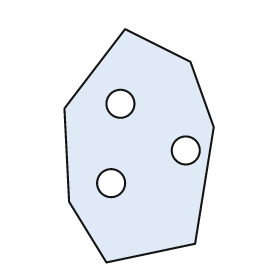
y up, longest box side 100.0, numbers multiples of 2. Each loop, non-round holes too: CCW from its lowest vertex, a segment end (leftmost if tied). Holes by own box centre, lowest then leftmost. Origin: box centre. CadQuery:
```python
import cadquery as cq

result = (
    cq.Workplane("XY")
    .moveTo(-14.0, -50.0)
    .lineTo(24.0, -42.0)
    .lineTo(32.0, 8.0)
    .lineTo(22.0, 36.0)
    .lineTo(-6.0, 50.0)
    .lineTo(-32.0, 16.0)
    .lineTo(-30.0, -24.0)
    .close()
    .moveTo(-12.0, -16.0)
    .circle(6.0)
    .moveTo(20.0, -2.0)
    .circle(6.0)
    .moveTo(-8.0, 18.0)
    .circle(6.0)
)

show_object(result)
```